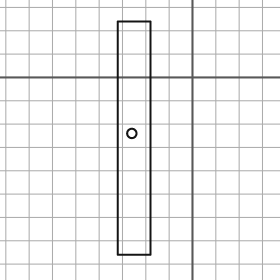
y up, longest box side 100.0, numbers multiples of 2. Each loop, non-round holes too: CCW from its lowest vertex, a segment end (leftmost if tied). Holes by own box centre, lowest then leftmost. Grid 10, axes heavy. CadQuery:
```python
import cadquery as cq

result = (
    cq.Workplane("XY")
    .moveTo(-32.0, -76.0)
    .lineTo(-18.0, -76.0)
    .lineTo(-18.0, 24.0)
    .lineTo(-32.0, 24.0)
    .close()
    .moveTo(-26.0, -24.0)
    .circle(2.0)
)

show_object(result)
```